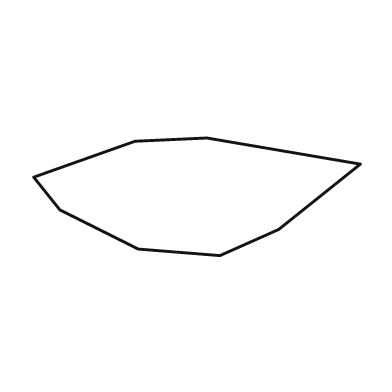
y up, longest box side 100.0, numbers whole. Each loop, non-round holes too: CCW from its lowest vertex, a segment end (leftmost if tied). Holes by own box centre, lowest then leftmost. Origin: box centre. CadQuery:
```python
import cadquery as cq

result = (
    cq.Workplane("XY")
    .moveTo(7.0, -18.0)
    .lineTo(25.0, -10.0)
    .lineTo(50.0, 10.0)
    .lineTo(3.0, 18.0)
    .lineTo(-19.0, 17.0)
    .lineTo(-50.0, 6.0)
    .lineTo(-42.0, -4.0)
    .lineTo(-18.0, -16.0)
    .close()
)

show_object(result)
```